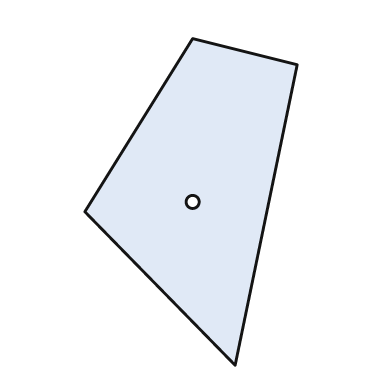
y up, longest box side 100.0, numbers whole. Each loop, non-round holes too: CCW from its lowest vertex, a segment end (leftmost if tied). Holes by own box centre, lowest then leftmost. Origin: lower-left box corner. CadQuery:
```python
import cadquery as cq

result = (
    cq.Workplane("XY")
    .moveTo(46.0, 0.0)
    .lineTo(65.0, 92.0)
    .lineTo(33.0, 100.0)
    .lineTo(0.0, 47.0)
    .close()
    .moveTo(33.0, 50.0)
    .circle(2.0)
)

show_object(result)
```